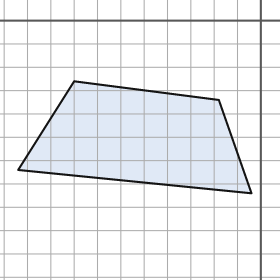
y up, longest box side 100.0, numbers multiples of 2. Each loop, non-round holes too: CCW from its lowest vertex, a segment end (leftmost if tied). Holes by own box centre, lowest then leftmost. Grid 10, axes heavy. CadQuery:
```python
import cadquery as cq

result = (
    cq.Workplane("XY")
    .moveTo(-4.0, -74.0)
    .lineTo(-18.0, -34.0)
    .lineTo(-80.0, -26.0)
    .lineTo(-104.0, -64.0)
    .close()
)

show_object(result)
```